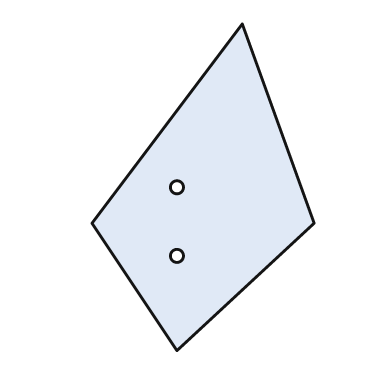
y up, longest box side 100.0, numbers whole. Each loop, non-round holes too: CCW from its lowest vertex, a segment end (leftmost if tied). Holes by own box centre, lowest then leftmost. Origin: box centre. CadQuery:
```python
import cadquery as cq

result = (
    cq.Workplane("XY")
    .moveTo(-8.0, -50.0)
    .lineTo(34.0, -11.0)
    .lineTo(12.0, 50.0)
    .lineTo(-34.0, -11.0)
    .close()
    .moveTo(-8.0, -21.0)
    .circle(2.0)
    .moveTo(-8.0, 0.0)
    .circle(2.0)
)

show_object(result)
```